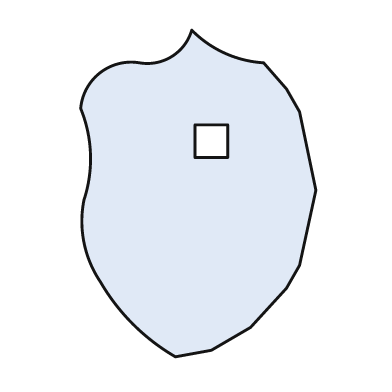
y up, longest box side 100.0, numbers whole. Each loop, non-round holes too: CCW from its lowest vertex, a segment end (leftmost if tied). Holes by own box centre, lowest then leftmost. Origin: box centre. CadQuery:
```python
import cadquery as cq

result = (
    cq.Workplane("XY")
    .moveTo(-7.0, -50.0)
    .lineTo(4.0, -48.0)
    .lineTo(16.0, -41.0)
    .lineTo(27.0, -29.0)
    .lineTo(31.0, -22.0)
    .lineTo(36.0, 1.0)
    .lineTo(31.0, 25.0)
    .lineTo(27.0, 32.0)
    .lineTo(20.0, 40.0)
    .threePointArc((8.0, 43.0), (-2.0, 50.0))
    .threePointArc((-8.0, 42.0), (-18.0, 40.0))
    .threePointArc((-30.0, 37.0), (-36.0, 26.0))
    .threePointArc((-33.0, 12.0), (-35.0, -2.0))
    .threePointArc((-35.0, -15.0), (-30.0, -27.0))
    .threePointArc((-20.0, -40.0), (-7.0, -50.0))
    .close()
    .moveTo(-1.0, 11.0)
    .lineTo(9.0, 11.0)
    .lineTo(9.0, 21.0)
    .lineTo(-1.0, 21.0)
    .close()
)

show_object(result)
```